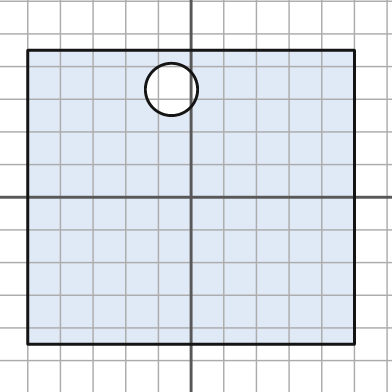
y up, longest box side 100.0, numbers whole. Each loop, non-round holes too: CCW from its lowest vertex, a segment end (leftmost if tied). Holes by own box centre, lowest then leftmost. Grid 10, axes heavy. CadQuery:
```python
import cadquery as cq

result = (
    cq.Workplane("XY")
    .moveTo(-50.0, -45.0)
    .lineTo(50.0, -45.0)
    .lineTo(50.0, 45.0)
    .lineTo(-50.0, 45.0)
    .close()
    .moveTo(-6.0, 33.0)
    .circle(8.0)
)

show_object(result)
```